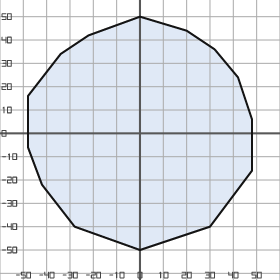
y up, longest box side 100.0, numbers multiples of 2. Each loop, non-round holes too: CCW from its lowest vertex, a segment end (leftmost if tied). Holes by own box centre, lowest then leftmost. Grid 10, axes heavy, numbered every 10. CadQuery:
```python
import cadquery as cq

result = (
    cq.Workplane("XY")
    .moveTo(0.0, -50.0)
    .lineTo(30.0, -40.0)
    .lineTo(48.0, -16.0)
    .lineTo(48.0, 6.0)
    .lineTo(42.0, 24.0)
    .lineTo(32.0, 36.0)
    .lineTo(20.0, 44.0)
    .lineTo(0.0, 50.0)
    .lineTo(-22.0, 42.0)
    .lineTo(-34.0, 34.0)
    .lineTo(-48.0, 16.0)
    .lineTo(-48.0, -6.0)
    .lineTo(-42.0, -22.0)
    .lineTo(-28.0, -40.0)
    .close()
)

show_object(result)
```